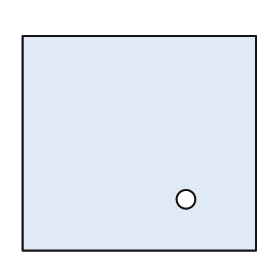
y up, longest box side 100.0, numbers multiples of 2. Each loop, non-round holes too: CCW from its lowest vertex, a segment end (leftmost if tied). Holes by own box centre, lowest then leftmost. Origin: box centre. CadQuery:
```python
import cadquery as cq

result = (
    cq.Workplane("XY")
    .moveTo(-50.0, -46.0)
    .lineTo(50.0, -46.0)
    .lineTo(50.0, 46.0)
    .lineTo(-50.0, 46.0)
    .close()
    .moveTo(20.0, -24.0)
    .circle(4.0)
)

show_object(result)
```